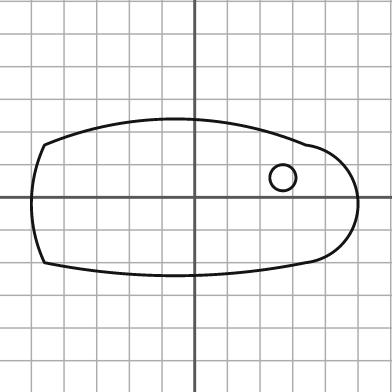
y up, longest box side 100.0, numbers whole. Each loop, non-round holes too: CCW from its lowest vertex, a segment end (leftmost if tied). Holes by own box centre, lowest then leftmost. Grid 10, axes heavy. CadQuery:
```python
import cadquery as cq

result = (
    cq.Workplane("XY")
    .moveTo(-46.0, -20.0)
    .threePointArc((-6.0, -24.0), (34.0, -20.0))
    .threePointArc((50.0, -2.0), (34.0, 16.0))
    .threePointArc((-6.0, 24.0), (-46.0, 16.0))
    .threePointArc((-50.0, -2.0), (-46.0, -20.0))
    .close()
    .moveTo(27.0, 6.0)
    .circle(4.0)
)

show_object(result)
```